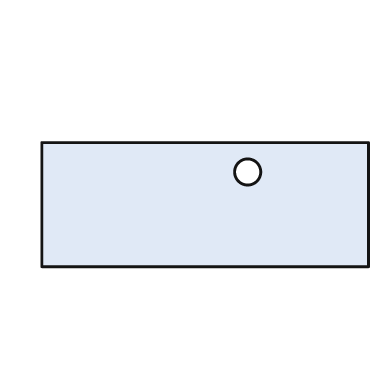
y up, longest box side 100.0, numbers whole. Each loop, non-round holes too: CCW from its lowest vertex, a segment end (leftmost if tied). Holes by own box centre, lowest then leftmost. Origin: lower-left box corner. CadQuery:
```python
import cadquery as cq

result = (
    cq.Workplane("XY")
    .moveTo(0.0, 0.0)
    .lineTo(100.0, 0.0)
    .lineTo(100.0, 38.0)
    .lineTo(0.0, 38.0)
    .close()
    .moveTo(63.0, 29.0)
    .circle(4.0)
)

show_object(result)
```